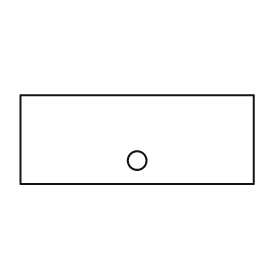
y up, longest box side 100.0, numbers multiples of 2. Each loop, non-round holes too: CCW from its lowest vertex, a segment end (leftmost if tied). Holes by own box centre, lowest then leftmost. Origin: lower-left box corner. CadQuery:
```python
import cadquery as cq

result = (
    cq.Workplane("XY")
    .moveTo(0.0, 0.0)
    .lineTo(100.0, 0.0)
    .lineTo(100.0, 38.0)
    .lineTo(0.0, 38.0)
    .close()
    .moveTo(50.0, 10.0)
    .circle(4.0)
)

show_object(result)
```